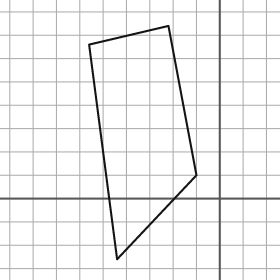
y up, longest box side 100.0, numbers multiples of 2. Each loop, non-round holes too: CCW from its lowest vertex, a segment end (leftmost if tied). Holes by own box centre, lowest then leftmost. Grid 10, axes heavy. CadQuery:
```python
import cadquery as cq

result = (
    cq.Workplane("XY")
    .moveTo(-44.0, -26.0)
    .lineTo(-10.0, 10.0)
    .lineTo(-22.0, 74.0)
    .lineTo(-56.0, 66.0)
    .close()
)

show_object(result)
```